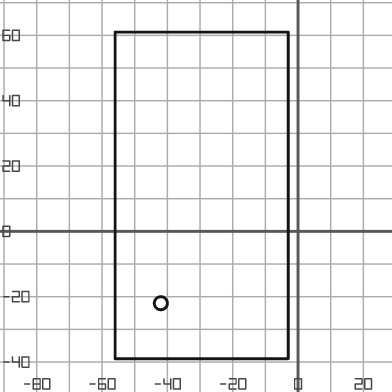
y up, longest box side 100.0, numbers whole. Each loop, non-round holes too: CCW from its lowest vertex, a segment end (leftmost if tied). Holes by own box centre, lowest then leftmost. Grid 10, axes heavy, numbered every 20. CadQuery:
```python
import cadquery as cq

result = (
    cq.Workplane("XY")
    .moveTo(-56.0, -39.0)
    .lineTo(-3.0, -39.0)
    .lineTo(-3.0, 61.0)
    .lineTo(-56.0, 61.0)
    .close()
    .moveTo(-42.0, -22.0)
    .circle(2.0)
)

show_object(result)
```